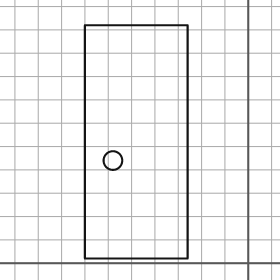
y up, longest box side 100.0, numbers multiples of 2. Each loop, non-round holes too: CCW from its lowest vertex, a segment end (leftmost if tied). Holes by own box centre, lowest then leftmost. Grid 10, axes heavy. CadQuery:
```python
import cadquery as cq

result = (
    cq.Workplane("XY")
    .moveTo(-70.0, 2.0)
    .lineTo(-26.0, 2.0)
    .lineTo(-26.0, 102.0)
    .lineTo(-70.0, 102.0)
    .close()
    .moveTo(-58.0, 44.0)
    .circle(4.0)
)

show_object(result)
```